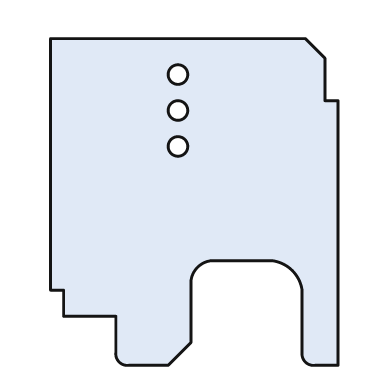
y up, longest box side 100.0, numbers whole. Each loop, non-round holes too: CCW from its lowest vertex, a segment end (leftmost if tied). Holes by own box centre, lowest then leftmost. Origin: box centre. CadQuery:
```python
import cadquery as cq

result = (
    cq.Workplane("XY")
    .moveTo(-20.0, -50.0)
    .lineTo(-8.0, -50.0)
    .lineTo(-1.0, -43.0)
    .lineTo(-1.0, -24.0)
    .threePointArc((1.0, -20.0), (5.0, -18.0))
    .lineTo(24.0, -18.0)
    .threePointArc((30.0, -21.0), (33.0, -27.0))
    .lineTo(33.0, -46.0)
    .threePointArc((34.0, -49.0), (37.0, -50.0))
    .lineTo(44.0, -50.0)
    .lineTo(44.0, 31.0)
    .lineTo(40.0, 31.0)
    .lineTo(40.0, 44.0)
    .lineTo(34.0, 50.0)
    .lineTo(-44.0, 50.0)
    .lineTo(-44.0, -27.0)
    .lineTo(-40.0, -27.0)
    .lineTo(-40.0, -35.0)
    .lineTo(-24.0, -35.0)
    .lineTo(-24.0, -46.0)
    .threePointArc((-23.0, -49.0), (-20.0, -50.0))
    .close()
    .moveTo(-5.0, 17.0)
    .circle(3.0)
    .moveTo(-5.0, 28.0)
    .circle(3.0)
    .moveTo(-5.0, 39.0)
    .circle(3.0)
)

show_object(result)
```